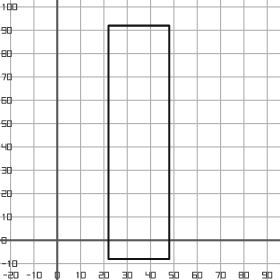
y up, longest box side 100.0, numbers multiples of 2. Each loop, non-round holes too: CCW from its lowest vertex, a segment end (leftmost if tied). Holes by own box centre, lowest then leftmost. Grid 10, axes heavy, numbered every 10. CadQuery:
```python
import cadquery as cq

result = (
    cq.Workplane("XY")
    .moveTo(22.0, -8.0)
    .lineTo(48.0, -8.0)
    .lineTo(48.0, 92.0)
    .lineTo(22.0, 92.0)
    .close()
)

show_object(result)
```